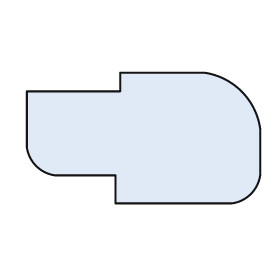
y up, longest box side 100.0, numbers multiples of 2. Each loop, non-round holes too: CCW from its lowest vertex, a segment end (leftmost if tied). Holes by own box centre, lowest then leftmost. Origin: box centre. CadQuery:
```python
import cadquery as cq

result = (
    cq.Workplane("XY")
    .moveTo(-12.0, -28.0)
    .lineTo(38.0, -28.0)
    .threePointArc((46.0, -24.0), (50.0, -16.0))
    .lineTo(50.0, 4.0)
    .threePointArc((42.0, 20.0), (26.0, 28.0))
    .lineTo(-10.0, 28.0)
    .lineTo(-10.0, 20.0)
    .lineTo(-50.0, 20.0)
    .lineTo(-50.0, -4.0)
    .threePointArc((-46.0, -12.0), (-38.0, -16.0))
    .lineTo(-12.0, -16.0)
    .close()
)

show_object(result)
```